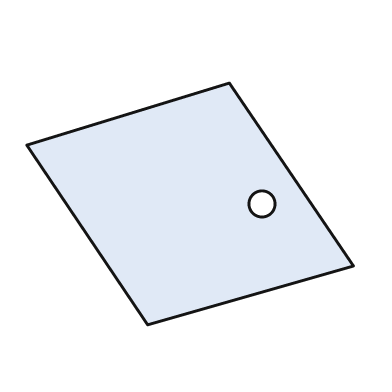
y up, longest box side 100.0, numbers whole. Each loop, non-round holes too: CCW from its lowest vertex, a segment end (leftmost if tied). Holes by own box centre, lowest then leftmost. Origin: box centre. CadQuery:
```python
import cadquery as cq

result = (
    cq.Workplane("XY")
    .moveTo(-13.0, -37.0)
    .lineTo(50.0, -19.0)
    .lineTo(12.0, 37.0)
    .lineTo(-50.0, 18.0)
    .close()
    .moveTo(22.0, 0.0)
    .circle(4.0)
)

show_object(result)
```